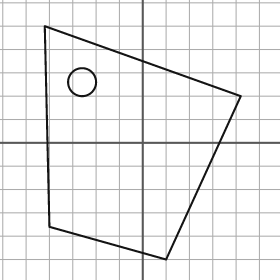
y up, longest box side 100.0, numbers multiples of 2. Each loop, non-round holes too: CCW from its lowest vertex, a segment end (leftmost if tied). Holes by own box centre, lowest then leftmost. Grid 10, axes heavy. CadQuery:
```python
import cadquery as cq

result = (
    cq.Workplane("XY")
    .moveTo(10.0, -50.0)
    .lineTo(42.0, 20.0)
    .lineTo(-42.0, 50.0)
    .lineTo(-40.0, -36.0)
    .close()
    .moveTo(-26.0, 26.0)
    .circle(6.0)
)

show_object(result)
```